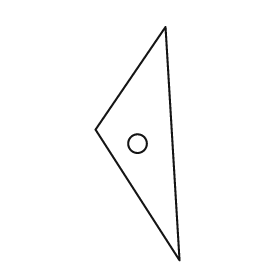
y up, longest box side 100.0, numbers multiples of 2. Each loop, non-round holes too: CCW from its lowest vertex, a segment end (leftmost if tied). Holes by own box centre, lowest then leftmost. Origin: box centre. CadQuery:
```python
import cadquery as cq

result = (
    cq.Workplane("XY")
    .moveTo(18.0, -50.0)
    .lineTo(12.0, 50.0)
    .lineTo(-18.0, 6.0)
    .close()
    .moveTo(0.0, 0.0)
    .circle(4.0)
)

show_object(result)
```